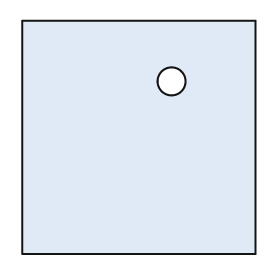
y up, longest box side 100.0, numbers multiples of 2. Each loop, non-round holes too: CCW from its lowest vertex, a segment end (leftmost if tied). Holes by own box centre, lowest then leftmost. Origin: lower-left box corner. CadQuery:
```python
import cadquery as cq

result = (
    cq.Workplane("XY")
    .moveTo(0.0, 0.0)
    .lineTo(100.0, 0.0)
    .lineTo(100.0, 100.0)
    .lineTo(0.0, 100.0)
    .close()
    .moveTo(64.0, 74.0)
    .circle(6.0)
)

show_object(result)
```